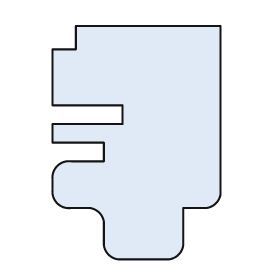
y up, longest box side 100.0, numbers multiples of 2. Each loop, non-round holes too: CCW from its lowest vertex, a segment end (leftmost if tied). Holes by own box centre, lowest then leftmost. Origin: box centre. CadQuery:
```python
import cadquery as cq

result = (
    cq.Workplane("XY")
    .moveTo(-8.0, -50.0)
    .lineTo(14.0, -50.0)
    .threePointArc((18.0, -48.0), (20.0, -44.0))
    .lineTo(20.0, -28.0)
    .lineTo(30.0, -28.0)
    .threePointArc((34.0, -26.0), (36.0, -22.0))
    .lineTo(36.0, 50.0)
    .lineTo(-26.0, 50.0)
    .lineTo(-26.0, 40.0)
    .lineTo(-36.0, 40.0)
    .lineTo(-36.0, 16.0)
    .lineTo(-6.0, 16.0)
    .lineTo(-6.0, 8.0)
    .lineTo(-36.0, 8.0)
    .lineTo(-36.0, 0.0)
    .lineTo(-14.0, 0.0)
    .lineTo(-14.0, -8.0)
    .lineTo(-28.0, -8.0)
    .threePointArc((-34.0, -10.0), (-36.0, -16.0))
    .lineTo(-36.0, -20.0)
    .threePointArc((-34.0, -26.0), (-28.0, -28.0))
    .lineTo(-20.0, -28.0)
    .threePointArc((-16.0, -30.0), (-14.0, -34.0))
    .lineTo(-14.0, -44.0)
    .threePointArc((-12.0, -48.0), (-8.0, -50.0))
    .close()
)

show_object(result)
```